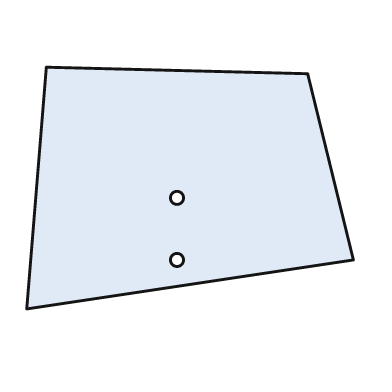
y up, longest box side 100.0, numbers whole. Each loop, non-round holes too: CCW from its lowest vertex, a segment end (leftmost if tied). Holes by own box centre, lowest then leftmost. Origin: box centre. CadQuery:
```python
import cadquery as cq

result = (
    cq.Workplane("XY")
    .moveTo(-50.0, -37.0)
    .lineTo(50.0, -22.0)
    .lineTo(36.0, 35.0)
    .lineTo(-44.0, 37.0)
    .close()
    .moveTo(-4.0, -22.0)
    .circle(2.0)
    .moveTo(-4.0, -3.0)
    .circle(2.0)
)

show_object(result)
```